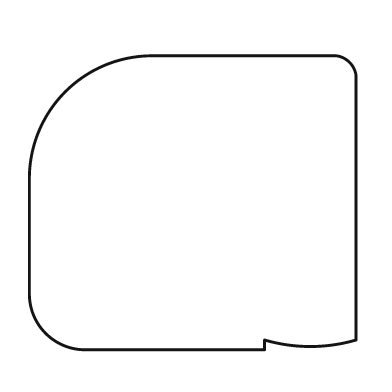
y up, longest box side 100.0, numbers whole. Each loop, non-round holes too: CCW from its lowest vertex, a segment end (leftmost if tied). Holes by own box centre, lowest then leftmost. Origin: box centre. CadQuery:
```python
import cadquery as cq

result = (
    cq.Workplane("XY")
    .moveTo(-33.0, -45.0)
    .lineTo(22.0, -45.0)
    .lineTo(22.0, -42.0)
    .threePointArc((36.0, -44.0), (50.0, -42.0))
    .lineTo(50.0, 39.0)
    .threePointArc((48.0, 43.0), (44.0, 45.0))
    .lineTo(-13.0, 45.0)
    .threePointArc((-39.0, 34.0), (-50.0, 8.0))
    .lineTo(-50.0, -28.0)
    .threePointArc((-45.0, -40.0), (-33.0, -45.0))
    .close()
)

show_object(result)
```